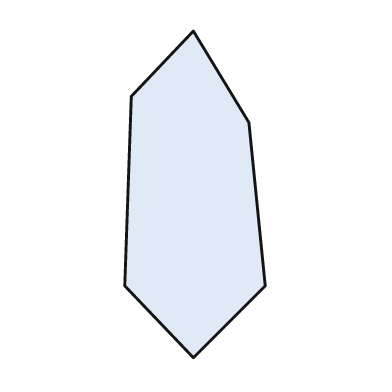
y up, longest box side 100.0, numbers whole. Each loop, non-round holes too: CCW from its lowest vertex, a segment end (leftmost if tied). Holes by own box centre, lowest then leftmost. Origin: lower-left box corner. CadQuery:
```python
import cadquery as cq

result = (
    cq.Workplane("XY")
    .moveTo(21.0, 0.0)
    .lineTo(43.0, 22.0)
    .lineTo(38.0, 72.0)
    .lineTo(21.0, 100.0)
    .lineTo(2.0, 80.0)
    .lineTo(0.0, 22.0)
    .close()
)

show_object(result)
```